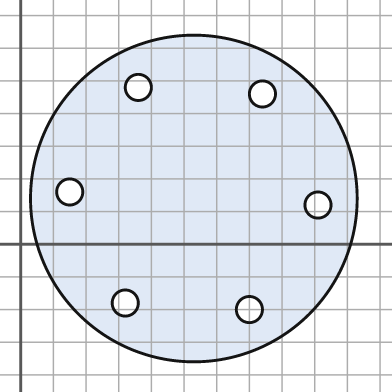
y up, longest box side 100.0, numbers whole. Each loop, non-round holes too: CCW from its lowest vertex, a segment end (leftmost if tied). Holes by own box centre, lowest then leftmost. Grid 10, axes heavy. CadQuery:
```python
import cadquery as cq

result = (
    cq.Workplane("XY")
    .moveTo(53.0, 14.0)
    .circle(50.0)
    .moveTo(70.0, -20.0)
    .circle(4.0)
    .moveTo(32.0, -18.0)
    .circle(4.0)
    .moveTo(91.0, 12.0)
    .circle(4.0)
    .moveTo(15.0, 16.0)
    .circle(4.0)
    .moveTo(74.0, 46.0)
    .circle(4.0)
    .moveTo(36.0, 48.0)
    .circle(4.0)
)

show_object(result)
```